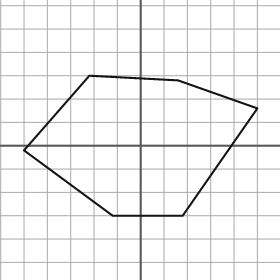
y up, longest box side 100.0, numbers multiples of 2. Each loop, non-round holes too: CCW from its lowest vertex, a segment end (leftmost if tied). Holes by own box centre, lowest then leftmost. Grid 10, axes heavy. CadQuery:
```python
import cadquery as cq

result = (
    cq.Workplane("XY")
    .moveTo(-12.0, -30.0)
    .lineTo(18.0, -30.0)
    .lineTo(50.0, 16.0)
    .lineTo(16.0, 28.0)
    .lineTo(-22.0, 30.0)
    .lineTo(-50.0, -2.0)
    .close()
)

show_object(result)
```